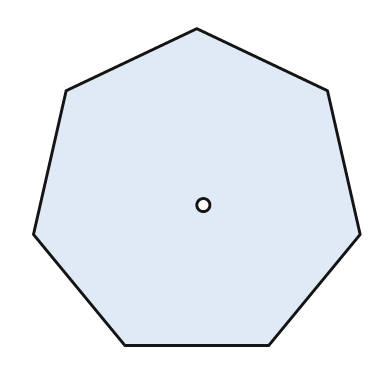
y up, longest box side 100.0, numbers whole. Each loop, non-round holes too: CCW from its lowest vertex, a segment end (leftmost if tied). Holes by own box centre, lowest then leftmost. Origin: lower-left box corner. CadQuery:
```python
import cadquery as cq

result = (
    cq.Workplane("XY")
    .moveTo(28.0, 0.0)
    .lineTo(72.0, 0.0)
    .lineTo(100.0, 34.0)
    .lineTo(90.0, 78.0)
    .lineTo(50.0, 97.0)
    .lineTo(10.0, 78.0)
    .lineTo(0.0, 34.0)
    .close()
    .moveTo(52.0, 43.0)
    .circle(2.0)
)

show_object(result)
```